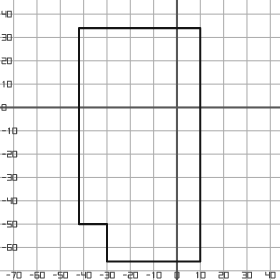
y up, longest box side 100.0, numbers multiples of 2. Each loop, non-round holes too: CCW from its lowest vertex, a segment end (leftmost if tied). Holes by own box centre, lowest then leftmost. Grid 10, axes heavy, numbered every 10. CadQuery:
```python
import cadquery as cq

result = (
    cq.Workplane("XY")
    .moveTo(-30.0, -66.0)
    .lineTo(10.0, -66.0)
    .lineTo(10.0, 34.0)
    .lineTo(-42.0, 34.0)
    .lineTo(-42.0, -50.0)
    .lineTo(-30.0, -50.0)
    .close()
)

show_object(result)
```